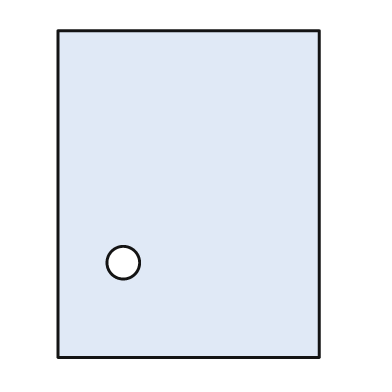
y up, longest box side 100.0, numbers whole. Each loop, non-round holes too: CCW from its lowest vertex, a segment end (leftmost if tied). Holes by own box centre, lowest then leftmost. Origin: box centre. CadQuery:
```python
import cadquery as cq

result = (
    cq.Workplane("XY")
    .moveTo(-40.0, -50.0)
    .lineTo(40.0, -50.0)
    .lineTo(40.0, 50.0)
    .lineTo(-40.0, 50.0)
    .close()
    .moveTo(-20.0, -21.0)
    .circle(5.0)
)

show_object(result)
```